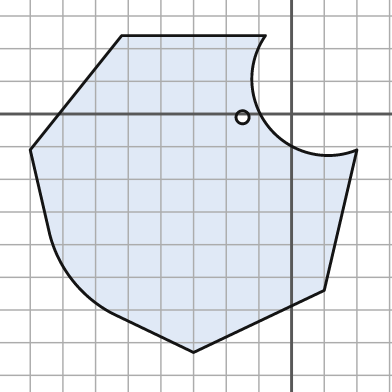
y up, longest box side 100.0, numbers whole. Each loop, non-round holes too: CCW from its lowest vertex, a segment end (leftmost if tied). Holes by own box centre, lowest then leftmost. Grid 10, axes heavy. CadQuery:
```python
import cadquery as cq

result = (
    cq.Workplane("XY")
    .moveTo(-30.0, -73.0)
    .lineTo(10.0, -54.0)
    .lineTo(20.0, -11.0)
    .threePointArc((-7.0, -4.0), (-8.0, 24.0))
    .lineTo(-52.0, 24.0)
    .lineTo(-80.0, -11.0)
    .lineTo(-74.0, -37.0)
    .threePointArc((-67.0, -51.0), (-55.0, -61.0))
    .close()
    .moveTo(-15.0, -1.0)
    .circle(2.0)
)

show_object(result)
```